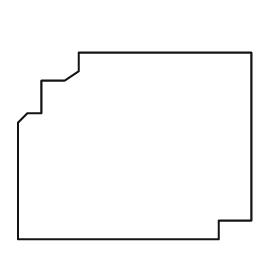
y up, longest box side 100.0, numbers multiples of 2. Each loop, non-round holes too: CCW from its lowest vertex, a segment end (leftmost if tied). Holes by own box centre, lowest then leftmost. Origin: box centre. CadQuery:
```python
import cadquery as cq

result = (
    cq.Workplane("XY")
    .moveTo(-50.0, -40.0)
    .lineTo(36.0, -40.0)
    .lineTo(36.0, -32.0)
    .lineTo(50.0, -32.0)
    .lineTo(50.0, 40.0)
    .lineTo(-24.0, 40.0)
    .lineTo(-24.0, 32.0)
    .lineTo(-30.0, 28.0)
    .lineTo(-40.0, 28.0)
    .lineTo(-40.0, 14.0)
    .lineTo(-46.0, 14.0)
    .lineTo(-50.0, 10.0)
    .close()
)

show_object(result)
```